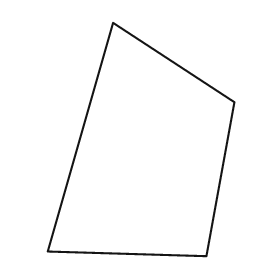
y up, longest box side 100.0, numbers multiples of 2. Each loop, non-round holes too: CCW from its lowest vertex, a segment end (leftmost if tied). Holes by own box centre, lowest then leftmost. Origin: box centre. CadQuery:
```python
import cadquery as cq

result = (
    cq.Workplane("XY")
    .moveTo(28.0, -50.0)
    .lineTo(40.0, 16.0)
    .lineTo(-12.0, 50.0)
    .lineTo(-40.0, -48.0)
    .close()
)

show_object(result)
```